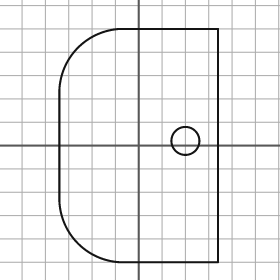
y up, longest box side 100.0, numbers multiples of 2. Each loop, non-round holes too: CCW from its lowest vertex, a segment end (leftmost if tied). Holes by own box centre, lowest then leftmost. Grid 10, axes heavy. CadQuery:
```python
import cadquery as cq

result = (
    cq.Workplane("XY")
    .moveTo(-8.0, -50.0)
    .lineTo(34.0, -50.0)
    .lineTo(34.0, 50.0)
    .lineTo(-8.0, 50.0)
    .threePointArc((-26.0, 42.0), (-34.0, 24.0))
    .lineTo(-34.0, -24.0)
    .threePointArc((-26.0, -42.0), (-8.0, -50.0))
    .close()
    .moveTo(20.0, 2.0)
    .circle(6.0)
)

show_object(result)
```